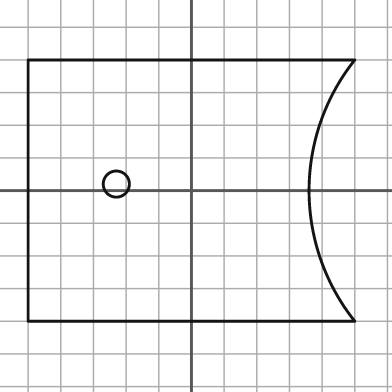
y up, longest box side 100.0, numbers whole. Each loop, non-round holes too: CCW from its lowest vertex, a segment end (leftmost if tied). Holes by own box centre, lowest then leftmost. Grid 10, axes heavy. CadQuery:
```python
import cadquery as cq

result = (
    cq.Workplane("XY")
    .moveTo(-50.0, -40.0)
    .lineTo(50.0, -40.0)
    .threePointArc((36.0, 0.0), (50.0, 40.0))
    .lineTo(-50.0, 40.0)
    .close()
    .moveTo(-23.0, 2.0)
    .circle(4.0)
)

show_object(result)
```